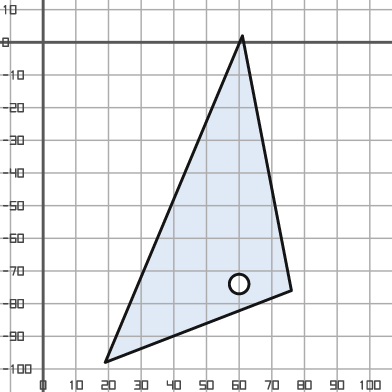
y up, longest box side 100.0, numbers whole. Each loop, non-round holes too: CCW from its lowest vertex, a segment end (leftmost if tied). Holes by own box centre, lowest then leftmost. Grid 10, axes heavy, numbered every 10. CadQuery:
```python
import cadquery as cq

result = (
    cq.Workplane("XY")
    .moveTo(19.0, -98.0)
    .lineTo(76.0, -76.0)
    .lineTo(61.0, 2.0)
    .close()
    .moveTo(60.0, -74.0)
    .circle(3.0)
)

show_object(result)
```